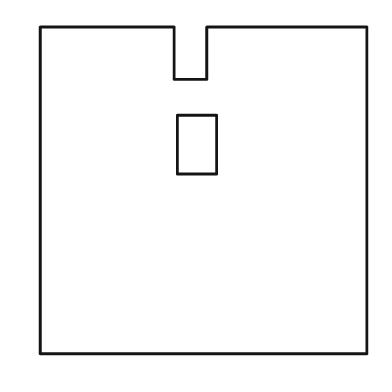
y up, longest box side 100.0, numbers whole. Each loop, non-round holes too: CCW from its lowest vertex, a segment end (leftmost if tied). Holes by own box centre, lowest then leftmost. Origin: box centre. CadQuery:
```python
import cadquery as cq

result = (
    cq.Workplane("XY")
    .moveTo(-50.0, -50.0)
    .lineTo(50.0, -50.0)
    .lineTo(50.0, 50.0)
    .lineTo(1.0, 50.0)
    .lineTo(1.0, 34.0)
    .lineTo(-9.0, 34.0)
    .lineTo(-9.0, 50.0)
    .lineTo(-50.0, 50.0)
    .close()
    .moveTo(-8.0, 5.0)
    .lineTo(4.0, 5.0)
    .lineTo(4.0, 23.0)
    .lineTo(-8.0, 23.0)
    .close()
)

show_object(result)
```